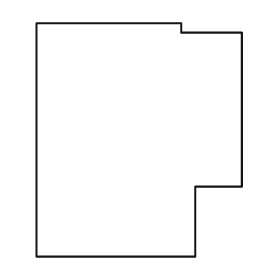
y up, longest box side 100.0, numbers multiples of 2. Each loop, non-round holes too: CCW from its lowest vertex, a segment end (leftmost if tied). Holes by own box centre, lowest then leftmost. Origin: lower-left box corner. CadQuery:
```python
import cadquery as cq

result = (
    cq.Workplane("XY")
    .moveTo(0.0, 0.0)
    .lineTo(68.0, 0.0)
    .lineTo(68.0, 30.0)
    .lineTo(88.0, 30.0)
    .lineTo(88.0, 96.0)
    .lineTo(62.0, 96.0)
    .lineTo(62.0, 100.0)
    .lineTo(0.0, 100.0)
    .close()
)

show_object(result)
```